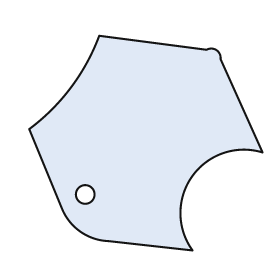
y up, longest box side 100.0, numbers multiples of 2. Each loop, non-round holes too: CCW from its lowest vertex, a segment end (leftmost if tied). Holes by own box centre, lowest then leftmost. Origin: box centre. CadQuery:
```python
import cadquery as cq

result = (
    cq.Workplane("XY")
    .moveTo(20.0, -46.0)
    .threePointArc((20.0, -14.0), (50.0, -4.0))
    .lineTo(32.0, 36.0)
    .threePointArc((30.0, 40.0), (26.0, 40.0))
    .lineTo(-20.0, 46.0)
    .threePointArc((-32.0, 24.0), (-50.0, 6.0))
    .lineTo(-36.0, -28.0)
    .threePointArc((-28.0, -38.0), (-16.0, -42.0))
    .close()
    .moveTo(-26.0, -22.0)
    .circle(4.0)
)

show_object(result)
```